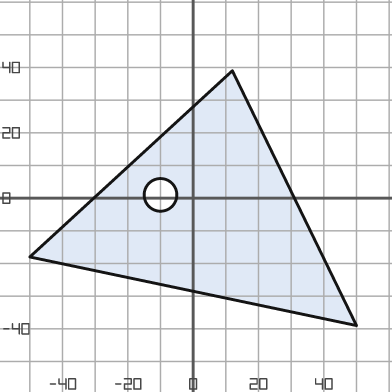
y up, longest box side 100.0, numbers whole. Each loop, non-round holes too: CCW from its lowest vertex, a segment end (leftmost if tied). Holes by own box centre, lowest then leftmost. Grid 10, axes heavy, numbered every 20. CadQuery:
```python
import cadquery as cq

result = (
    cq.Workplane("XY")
    .moveTo(50.0, -39.0)
    .lineTo(12.0, 39.0)
    .lineTo(-50.0, -18.0)
    .close()
    .moveTo(-10.0, 1.0)
    .circle(5.0)
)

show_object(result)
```